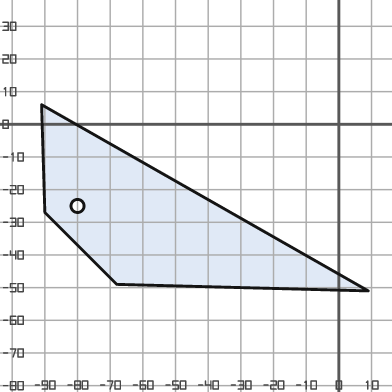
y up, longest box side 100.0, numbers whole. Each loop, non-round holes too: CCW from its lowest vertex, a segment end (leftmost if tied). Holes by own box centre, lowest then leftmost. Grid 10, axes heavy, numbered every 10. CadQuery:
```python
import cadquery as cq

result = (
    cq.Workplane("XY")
    .moveTo(9.0, -51.0)
    .lineTo(-91.0, 6.0)
    .lineTo(-90.0, -27.0)
    .lineTo(-68.0, -49.0)
    .close()
    .moveTo(-80.0, -25.0)
    .circle(2.0)
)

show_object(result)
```